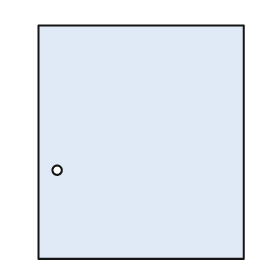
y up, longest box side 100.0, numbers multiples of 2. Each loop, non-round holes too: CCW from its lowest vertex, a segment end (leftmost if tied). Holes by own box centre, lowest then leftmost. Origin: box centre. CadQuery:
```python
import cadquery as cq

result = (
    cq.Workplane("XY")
    .moveTo(-44.0, -50.0)
    .lineTo(44.0, -50.0)
    .lineTo(44.0, 50.0)
    .lineTo(-44.0, 50.0)
    .close()
    .moveTo(-36.0, -12.0)
    .circle(2.0)
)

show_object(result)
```